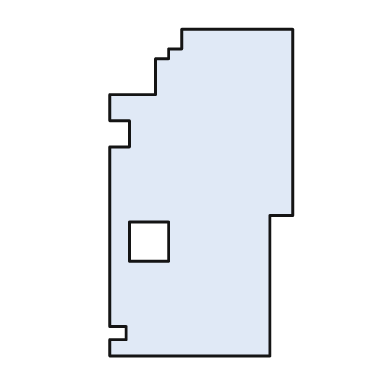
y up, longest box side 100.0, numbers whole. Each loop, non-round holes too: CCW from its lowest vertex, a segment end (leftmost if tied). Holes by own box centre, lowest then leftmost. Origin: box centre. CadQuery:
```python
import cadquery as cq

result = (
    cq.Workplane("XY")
    .moveTo(-28.0, -50.0)
    .lineTo(21.0, -50.0)
    .lineTo(21.0, -7.0)
    .lineTo(28.0, -7.0)
    .lineTo(28.0, 50.0)
    .lineTo(-6.0, 50.0)
    .lineTo(-6.0, 44.0)
    .lineTo(-10.0, 44.0)
    .lineTo(-10.0, 41.0)
    .lineTo(-14.0, 41.0)
    .lineTo(-14.0, 30.0)
    .lineTo(-28.0, 30.0)
    .lineTo(-28.0, 22.0)
    .lineTo(-22.0, 22.0)
    .lineTo(-22.0, 14.0)
    .lineTo(-28.0, 14.0)
    .lineTo(-28.0, -41.0)
    .lineTo(-23.0, -41.0)
    .lineTo(-23.0, -45.0)
    .lineTo(-28.0, -45.0)
    .close()
    .moveTo(-22.0, -21.0)
    .lineTo(-10.0, -21.0)
    .lineTo(-10.0, -9.0)
    .lineTo(-22.0, -9.0)
    .close()
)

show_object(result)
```